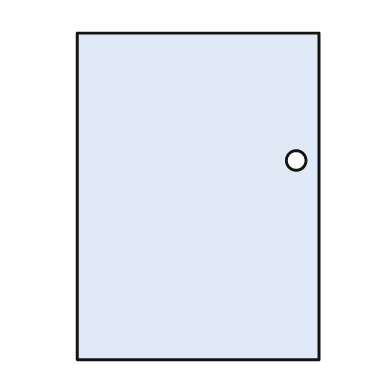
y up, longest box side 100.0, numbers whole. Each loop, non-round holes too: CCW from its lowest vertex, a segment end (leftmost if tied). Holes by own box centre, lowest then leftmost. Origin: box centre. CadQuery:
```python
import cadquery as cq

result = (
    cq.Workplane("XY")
    .moveTo(-37.0, -50.0)
    .lineTo(37.0, -50.0)
    .lineTo(37.0, 50.0)
    .lineTo(-37.0, 50.0)
    .close()
    .moveTo(30.0, 11.0)
    .circle(3.0)
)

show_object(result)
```